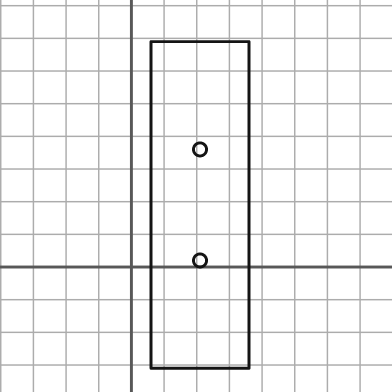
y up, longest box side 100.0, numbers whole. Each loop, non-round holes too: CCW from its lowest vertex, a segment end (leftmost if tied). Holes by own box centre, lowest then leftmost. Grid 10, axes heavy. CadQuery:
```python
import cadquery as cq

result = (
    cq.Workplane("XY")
    .moveTo(6.0, -31.0)
    .lineTo(36.0, -31.0)
    .lineTo(36.0, 69.0)
    .lineTo(6.0, 69.0)
    .close()
    .moveTo(21.0, 2.0)
    .circle(2.0)
    .moveTo(21.0, 36.0)
    .circle(2.0)
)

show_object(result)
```